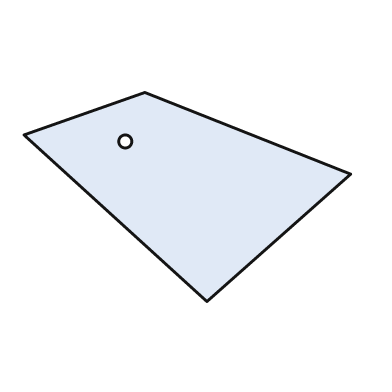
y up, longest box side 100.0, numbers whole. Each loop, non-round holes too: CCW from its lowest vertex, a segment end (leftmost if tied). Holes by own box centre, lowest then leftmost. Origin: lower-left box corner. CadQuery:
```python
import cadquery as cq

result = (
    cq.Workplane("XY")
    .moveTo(56.0, 0.0)
    .lineTo(100.0, 39.0)
    .lineTo(37.0, 64.0)
    .lineTo(0.0, 51.0)
    .close()
    .moveTo(31.0, 49.0)
    .circle(2.0)
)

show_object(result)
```